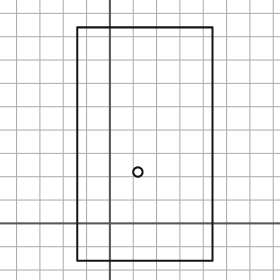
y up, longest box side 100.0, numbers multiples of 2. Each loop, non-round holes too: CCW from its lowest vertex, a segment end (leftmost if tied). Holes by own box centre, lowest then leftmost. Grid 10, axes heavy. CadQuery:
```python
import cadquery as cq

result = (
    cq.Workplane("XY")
    .moveTo(-14.0, -16.0)
    .lineTo(44.0, -16.0)
    .lineTo(44.0, 84.0)
    .lineTo(-14.0, 84.0)
    .close()
    .moveTo(12.0, 22.0)
    .circle(2.0)
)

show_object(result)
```